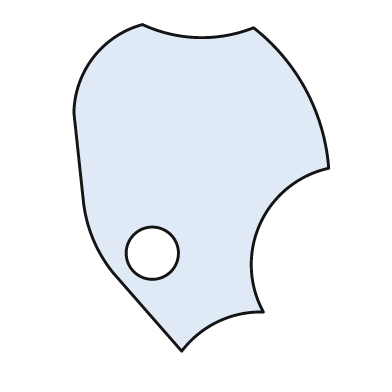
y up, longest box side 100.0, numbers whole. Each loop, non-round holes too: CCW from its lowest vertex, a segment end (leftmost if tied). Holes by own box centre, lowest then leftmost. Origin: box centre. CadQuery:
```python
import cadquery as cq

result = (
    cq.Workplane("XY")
    .moveTo(-6.0, -50.0)
    .threePointArc((5.0, -41.0), (19.0, -38.0))
    .threePointArc((18.0, -11.0), (39.0, 6.0))
    .threePointArc((32.0, 30.0), (16.0, 49.0))
    .threePointArc((-1.0, 46.0), (-18.0, 50.0))
    .threePointArc((-33.0, 40.0), (-39.0, 23.0))
    .lineTo(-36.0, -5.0)
    .threePointArc((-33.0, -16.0), (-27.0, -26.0))
    .close()
    .moveTo(-15.0, -20.0)
    .circle(8.0)
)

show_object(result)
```